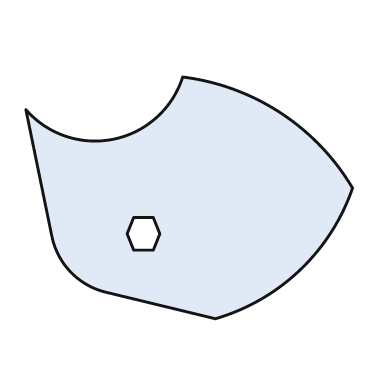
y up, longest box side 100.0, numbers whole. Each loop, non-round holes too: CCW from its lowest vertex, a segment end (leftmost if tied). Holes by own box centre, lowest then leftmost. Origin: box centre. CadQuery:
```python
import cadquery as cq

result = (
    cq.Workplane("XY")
    .moveTo(8.0, -37.0)
    .threePointArc((34.0, -22.0), (50.0, 3.0))
    .threePointArc((28.0, 26.0), (-2.0, 37.0))
    .threePointArc((-23.0, 18.0), (-50.0, 27.0))
    .lineTo(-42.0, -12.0)
    .threePointArc((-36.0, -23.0), (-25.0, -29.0))
    .close()
    .moveTo(-17.0, -16.0)
    .lineTo(-11.0, -16.0)
    .lineTo(-9.0, -11.0)
    .lineTo(-11.0, -6.0)
    .lineTo(-17.0, -6.0)
    .lineTo(-19.0, -11.0)
    .close()
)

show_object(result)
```